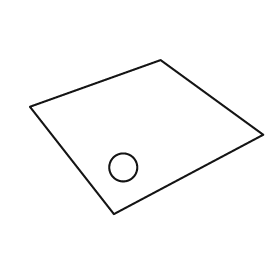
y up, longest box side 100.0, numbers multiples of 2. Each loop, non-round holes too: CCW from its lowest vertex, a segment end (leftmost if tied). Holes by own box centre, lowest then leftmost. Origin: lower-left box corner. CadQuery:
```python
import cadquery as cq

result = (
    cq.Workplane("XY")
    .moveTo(36.0, 0.0)
    .lineTo(100.0, 34.0)
    .lineTo(56.0, 66.0)
    .lineTo(0.0, 46.0)
    .close()
    .moveTo(40.0, 20.0)
    .circle(6.0)
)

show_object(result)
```